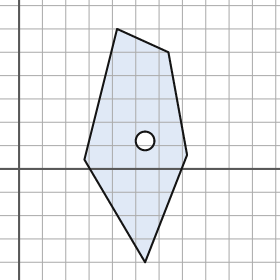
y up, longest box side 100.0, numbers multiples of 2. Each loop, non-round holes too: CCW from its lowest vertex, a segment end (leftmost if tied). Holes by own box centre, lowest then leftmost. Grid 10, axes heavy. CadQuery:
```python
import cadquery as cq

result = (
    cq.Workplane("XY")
    .moveTo(54.0, -40.0)
    .lineTo(72.0, 6.0)
    .lineTo(64.0, 50.0)
    .lineTo(42.0, 60.0)
    .lineTo(28.0, 4.0)
    .close()
    .moveTo(54.0, 12.0)
    .circle(4.0)
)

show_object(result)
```